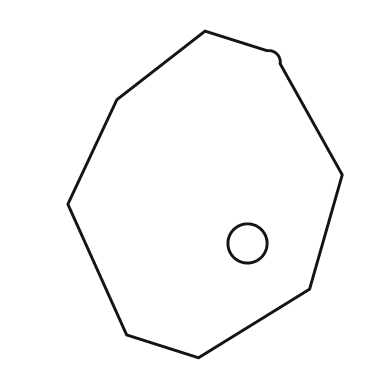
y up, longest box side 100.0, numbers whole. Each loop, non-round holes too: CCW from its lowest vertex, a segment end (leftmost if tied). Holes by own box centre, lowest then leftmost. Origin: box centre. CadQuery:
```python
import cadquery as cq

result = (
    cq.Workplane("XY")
    .moveTo(-2.0, -50.0)
    .lineTo(32.0, -29.0)
    .lineTo(42.0, 6.0)
    .lineTo(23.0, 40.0)
    .threePointArc((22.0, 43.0), (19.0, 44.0))
    .lineTo(0.0, 50.0)
    .lineTo(-27.0, 29.0)
    .lineTo(-42.0, -3.0)
    .lineTo(-24.0, -43.0)
    .close()
    .moveTo(13.0, -15.0)
    .circle(6.0)
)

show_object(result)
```